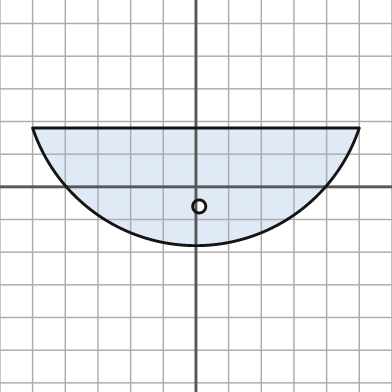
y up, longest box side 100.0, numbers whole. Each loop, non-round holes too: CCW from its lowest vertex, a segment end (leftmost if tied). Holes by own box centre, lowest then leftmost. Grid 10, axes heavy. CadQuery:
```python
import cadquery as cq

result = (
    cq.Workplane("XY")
    .moveTo(-50.0, 18.0)
    .threePointArc((0.0, -18.0), (50.0, 18.0))
    .close()
    .moveTo(1.0, -6.0)
    .circle(2.0)
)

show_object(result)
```